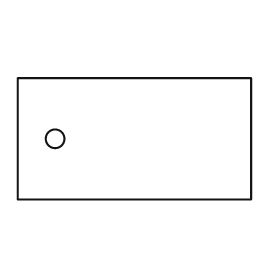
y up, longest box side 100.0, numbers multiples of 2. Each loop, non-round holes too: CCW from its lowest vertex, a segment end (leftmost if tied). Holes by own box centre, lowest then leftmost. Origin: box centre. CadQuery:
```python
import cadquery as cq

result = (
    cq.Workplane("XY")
    .moveTo(-50.0, -26.0)
    .lineTo(50.0, -26.0)
    .lineTo(50.0, 26.0)
    .lineTo(-50.0, 26.0)
    .close()
    .moveTo(-34.0, 0.0)
    .circle(4.0)
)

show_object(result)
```